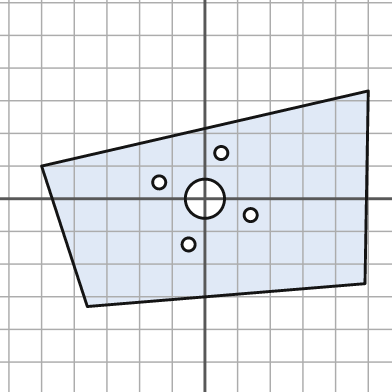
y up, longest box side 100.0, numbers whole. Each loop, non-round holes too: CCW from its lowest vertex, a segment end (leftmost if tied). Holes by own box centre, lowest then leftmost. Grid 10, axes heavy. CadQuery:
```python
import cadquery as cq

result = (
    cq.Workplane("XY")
    .moveTo(-36.0, -33.0)
    .lineTo(49.0, -26.0)
    .lineTo(50.0, 33.0)
    .lineTo(-50.0, 10.0)
    .close()
    .moveTo(-5.0, -14.0)
    .circle(2.0)
    .moveTo(14.0, -5.0)
    .circle(2.0)
    .moveTo(0.0, 0.0)
    .circle(6.0)
    .moveTo(-14.0, 5.0)
    .circle(2.0)
    .moveTo(5.0, 14.0)
    .circle(2.0)
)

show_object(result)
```